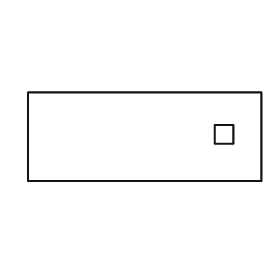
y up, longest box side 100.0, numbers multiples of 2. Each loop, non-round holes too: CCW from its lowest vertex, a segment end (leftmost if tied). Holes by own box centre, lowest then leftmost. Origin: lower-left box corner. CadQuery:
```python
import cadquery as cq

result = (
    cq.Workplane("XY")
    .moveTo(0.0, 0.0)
    .lineTo(100.0, 0.0)
    .lineTo(100.0, 38.0)
    .lineTo(0.0, 38.0)
    .close()
    .moveTo(80.0, 16.0)
    .lineTo(88.0, 16.0)
    .lineTo(88.0, 24.0)
    .lineTo(80.0, 24.0)
    .close()
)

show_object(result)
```